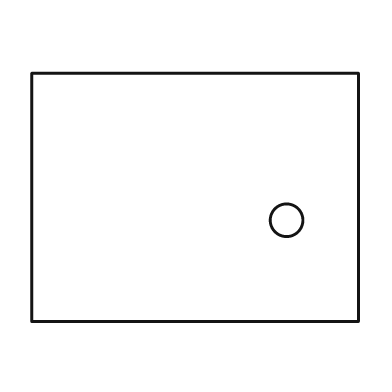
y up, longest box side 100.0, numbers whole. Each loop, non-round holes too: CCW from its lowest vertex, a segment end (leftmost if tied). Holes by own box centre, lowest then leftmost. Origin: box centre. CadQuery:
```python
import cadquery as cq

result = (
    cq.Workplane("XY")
    .moveTo(-50.0, -38.0)
    .lineTo(50.0, -38.0)
    .lineTo(50.0, 38.0)
    .lineTo(-50.0, 38.0)
    .close()
    .moveTo(28.0, -7.0)
    .circle(5.0)
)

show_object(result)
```